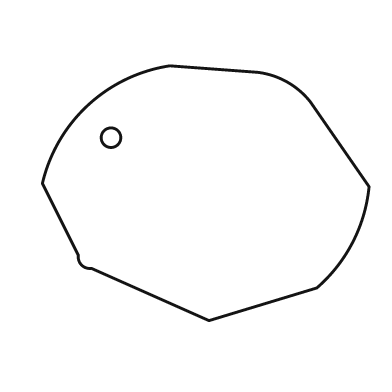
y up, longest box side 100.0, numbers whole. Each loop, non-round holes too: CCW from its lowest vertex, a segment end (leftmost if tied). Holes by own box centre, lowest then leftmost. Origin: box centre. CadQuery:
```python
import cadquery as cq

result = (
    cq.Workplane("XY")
    .moveTo(1.0, -39.0)
    .lineTo(34.0, -29.0)
    .threePointArc((45.0, -15.0), (50.0, 2.0))
    .lineTo(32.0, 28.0)
    .threePointArc((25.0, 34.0), (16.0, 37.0))
    .lineTo(-11.0, 39.0)
    .threePointArc((-36.0, 27.0), (-50.0, 3.0))
    .lineTo(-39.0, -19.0)
    .threePointArc((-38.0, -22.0), (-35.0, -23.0))
    .close()
    .moveTo(-29.0, 17.0)
    .circle(3.0)
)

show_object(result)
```